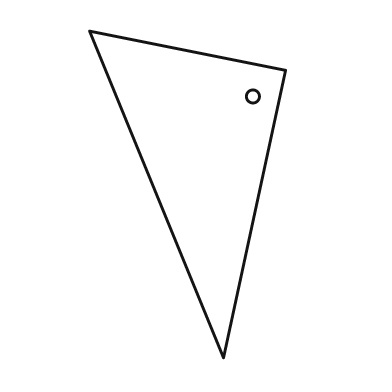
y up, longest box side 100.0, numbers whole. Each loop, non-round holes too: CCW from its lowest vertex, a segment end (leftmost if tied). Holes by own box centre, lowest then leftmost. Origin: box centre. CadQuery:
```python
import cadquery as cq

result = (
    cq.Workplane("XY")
    .moveTo(11.0, -50.0)
    .lineTo(30.0, 38.0)
    .lineTo(-30.0, 50.0)
    .close()
    .moveTo(20.0, 30.0)
    .circle(2.0)
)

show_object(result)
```